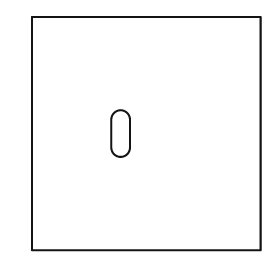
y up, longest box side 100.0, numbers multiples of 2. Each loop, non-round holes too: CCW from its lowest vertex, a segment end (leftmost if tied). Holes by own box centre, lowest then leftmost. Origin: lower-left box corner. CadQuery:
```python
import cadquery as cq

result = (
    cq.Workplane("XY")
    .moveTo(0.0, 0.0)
    .lineTo(98.0, 0.0)
    .lineTo(98.0, 100.0)
    .lineTo(0.0, 100.0)
    .close()
    .moveTo(34.0, 44.0)
    .threePointArc((38.0, 40.0), (42.0, 44.0))
    .lineTo(42.0, 56.0)
    .threePointArc((38.0, 60.0), (34.0, 56.0))
    .close()
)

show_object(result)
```